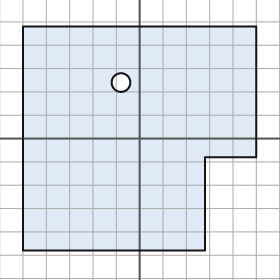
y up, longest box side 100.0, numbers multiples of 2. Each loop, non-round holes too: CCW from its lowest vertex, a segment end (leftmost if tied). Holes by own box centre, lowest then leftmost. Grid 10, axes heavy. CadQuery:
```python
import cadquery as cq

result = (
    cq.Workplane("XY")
    .moveTo(-50.0, -48.0)
    .lineTo(28.0, -48.0)
    .lineTo(28.0, -8.0)
    .lineTo(50.0, -8.0)
    .lineTo(50.0, 48.0)
    .lineTo(-50.0, 48.0)
    .close()
    .moveTo(-8.0, 24.0)
    .circle(4.0)
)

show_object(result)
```